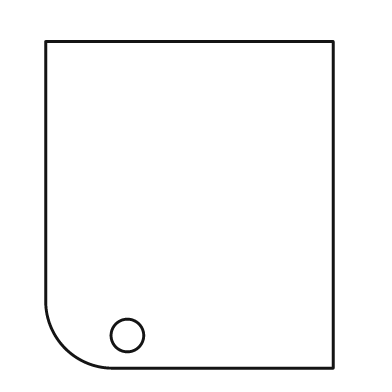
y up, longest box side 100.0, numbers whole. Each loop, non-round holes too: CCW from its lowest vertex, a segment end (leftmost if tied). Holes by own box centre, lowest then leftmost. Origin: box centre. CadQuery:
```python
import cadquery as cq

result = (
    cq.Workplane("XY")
    .moveTo(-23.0, -50.0)
    .lineTo(44.0, -50.0)
    .lineTo(44.0, 50.0)
    .lineTo(-44.0, 50.0)
    .lineTo(-44.0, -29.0)
    .threePointArc((-38.0, -44.0), (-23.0, -50.0))
    .close()
    .moveTo(-19.0, -40.0)
    .circle(5.0)
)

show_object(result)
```